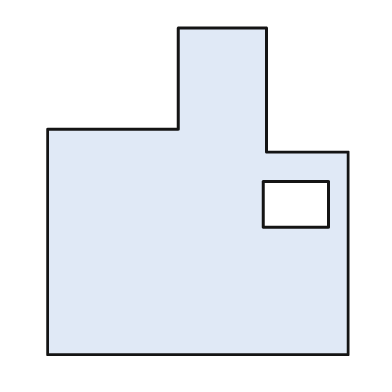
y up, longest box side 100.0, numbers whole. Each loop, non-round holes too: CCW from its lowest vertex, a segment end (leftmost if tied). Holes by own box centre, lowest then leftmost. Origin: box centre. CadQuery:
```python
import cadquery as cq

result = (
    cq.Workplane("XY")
    .moveTo(-46.0, -50.0)
    .lineTo(46.0, -50.0)
    .lineTo(46.0, 12.0)
    .lineTo(21.0, 12.0)
    .lineTo(21.0, 50.0)
    .lineTo(-6.0, 50.0)
    .lineTo(-6.0, 19.0)
    .lineTo(-46.0, 19.0)
    .close()
    .moveTo(20.0, -11.0)
    .lineTo(40.0, -11.0)
    .lineTo(40.0, 3.0)
    .lineTo(20.0, 3.0)
    .close()
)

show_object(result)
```